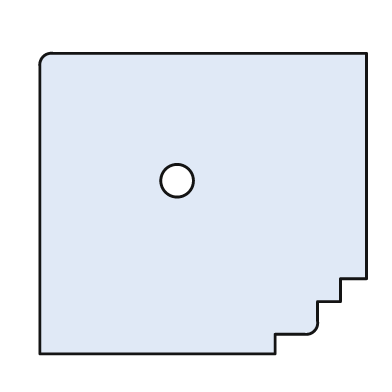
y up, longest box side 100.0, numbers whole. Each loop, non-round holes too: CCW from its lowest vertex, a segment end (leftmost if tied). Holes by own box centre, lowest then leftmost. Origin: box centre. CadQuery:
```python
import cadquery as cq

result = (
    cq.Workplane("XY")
    .moveTo(-50.0, -46.0)
    .lineTo(22.0, -46.0)
    .lineTo(22.0, -40.0)
    .lineTo(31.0, -40.0)
    .threePointArc((34.0, -39.0), (35.0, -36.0))
    .lineTo(35.0, -30.0)
    .lineTo(42.0, -30.0)
    .lineTo(42.0, -23.0)
    .lineTo(50.0, -23.0)
    .lineTo(50.0, 46.0)
    .lineTo(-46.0, 46.0)
    .threePointArc((-49.0, 45.0), (-50.0, 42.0))
    .close()
    .moveTo(-8.0, 7.0)
    .circle(5.0)
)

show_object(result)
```